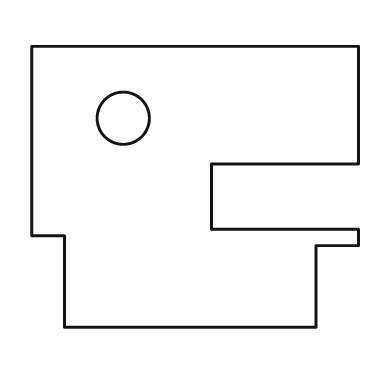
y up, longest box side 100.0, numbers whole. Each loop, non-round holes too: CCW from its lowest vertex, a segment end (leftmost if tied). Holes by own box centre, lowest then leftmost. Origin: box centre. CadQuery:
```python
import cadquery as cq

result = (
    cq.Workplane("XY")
    .moveTo(-40.0, -43.0)
    .lineTo(37.0, -43.0)
    .lineTo(37.0, -18.0)
    .lineTo(50.0, -18.0)
    .lineTo(50.0, -13.0)
    .lineTo(5.0, -13.0)
    .lineTo(5.0, 7.0)
    .lineTo(50.0, 7.0)
    .lineTo(50.0, 43.0)
    .lineTo(-50.0, 43.0)
    .lineTo(-50.0, -15.0)
    .lineTo(-40.0, -15.0)
    .close()
    .moveTo(-22.0, 21.0)
    .circle(8.0)
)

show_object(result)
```